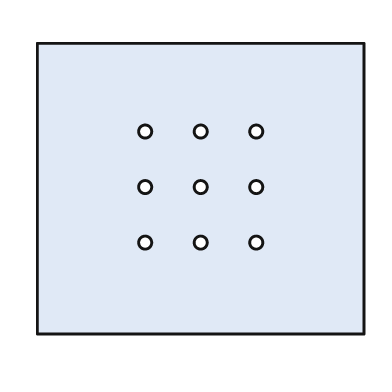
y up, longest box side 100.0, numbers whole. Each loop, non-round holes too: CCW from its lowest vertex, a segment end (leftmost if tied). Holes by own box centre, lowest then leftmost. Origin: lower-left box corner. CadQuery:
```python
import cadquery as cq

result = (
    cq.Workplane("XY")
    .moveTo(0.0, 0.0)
    .lineTo(100.0, 0.0)
    .lineTo(100.0, 89.0)
    .lineTo(0.0, 89.0)
    .close()
    .moveTo(33.0, 28.0)
    .circle(2.0)
    .moveTo(50.0, 28.0)
    .circle(2.0)
    .moveTo(67.0, 28.0)
    .circle(2.0)
    .moveTo(33.0, 45.0)
    .circle(2.0)
    .moveTo(50.0, 45.0)
    .circle(2.0)
    .moveTo(67.0, 45.0)
    .circle(2.0)
    .moveTo(33.0, 62.0)
    .circle(2.0)
    .moveTo(50.0, 62.0)
    .circle(2.0)
    .moveTo(67.0, 62.0)
    .circle(2.0)
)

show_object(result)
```